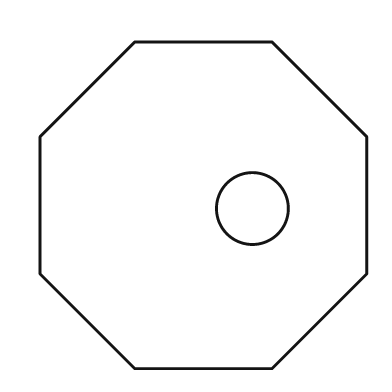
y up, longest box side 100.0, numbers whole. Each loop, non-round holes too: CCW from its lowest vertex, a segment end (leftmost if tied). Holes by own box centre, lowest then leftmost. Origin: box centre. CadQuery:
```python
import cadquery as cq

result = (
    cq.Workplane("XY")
    .moveTo(-21.0, -50.0)
    .lineTo(21.0, -50.0)
    .lineTo(50.0, -21.0)
    .lineTo(50.0, 21.0)
    .lineTo(21.0, 50.0)
    .lineTo(-21.0, 50.0)
    .lineTo(-50.0, 21.0)
    .lineTo(-50.0, -21.0)
    .close()
    .moveTo(15.0, -1.0)
    .circle(11.0)
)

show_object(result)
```